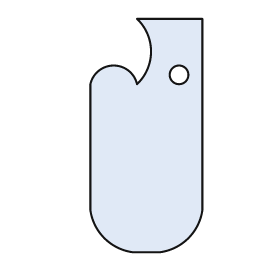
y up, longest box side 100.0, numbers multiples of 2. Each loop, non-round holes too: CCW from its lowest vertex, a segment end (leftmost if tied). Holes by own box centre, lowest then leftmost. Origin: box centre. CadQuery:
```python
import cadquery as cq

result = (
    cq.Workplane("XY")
    .moveTo(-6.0, -50.0)
    .lineTo(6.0, -50.0)
    .threePointArc((18.0, -44.0), (24.0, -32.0))
    .lineTo(24.0, 50.0)
    .lineTo(-4.0, 50.0)
    .threePointArc((2.0, 36.0), (-4.0, 22.0))
    .threePointArc((-14.0, 30.0), (-24.0, 22.0))
    .lineTo(-24.0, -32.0)
    .threePointArc((-18.0, -44.0), (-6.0, -50.0))
    .close()
    .moveTo(14.0, 26.0)
    .circle(4.0)
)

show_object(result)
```